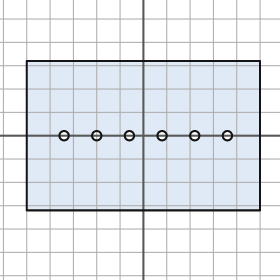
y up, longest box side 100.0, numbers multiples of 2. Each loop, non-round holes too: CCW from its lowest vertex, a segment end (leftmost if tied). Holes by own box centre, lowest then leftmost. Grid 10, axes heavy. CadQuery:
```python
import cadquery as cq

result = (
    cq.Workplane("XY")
    .moveTo(-50.0, -32.0)
    .lineTo(50.0, -32.0)
    .lineTo(50.0, 32.0)
    .lineTo(-50.0, 32.0)
    .close()
    .moveTo(-34.0, 0.0)
    .circle(2.0)
    .moveTo(-20.0, 0.0)
    .circle(2.0)
    .moveTo(-6.0, 0.0)
    .circle(2.0)
    .moveTo(8.0, 0.0)
    .circle(2.0)
    .moveTo(22.0, 0.0)
    .circle(2.0)
    .moveTo(36.0, 0.0)
    .circle(2.0)
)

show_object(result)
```